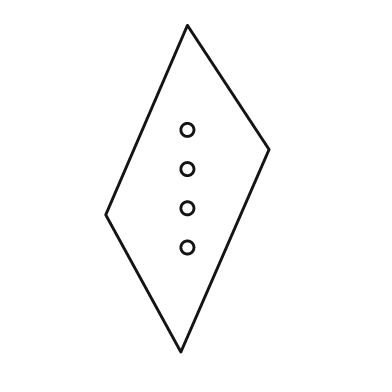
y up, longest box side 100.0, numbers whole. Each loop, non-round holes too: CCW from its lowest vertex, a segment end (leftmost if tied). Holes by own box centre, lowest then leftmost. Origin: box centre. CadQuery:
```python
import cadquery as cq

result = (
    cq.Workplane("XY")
    .moveTo(-2.0, -50.0)
    .lineTo(25.0, 12.0)
    .lineTo(0.0, 50.0)
    .lineTo(-25.0, -8.0)
    .close()
    .moveTo(0.0, -18.0)
    .circle(2.0)
    .moveTo(0.0, -6.0)
    .circle(2.0)
    .moveTo(0.0, 6.0)
    .circle(2.0)
    .moveTo(0.0, 18.0)
    .circle(2.0)
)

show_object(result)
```